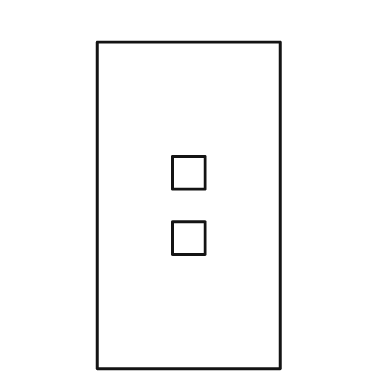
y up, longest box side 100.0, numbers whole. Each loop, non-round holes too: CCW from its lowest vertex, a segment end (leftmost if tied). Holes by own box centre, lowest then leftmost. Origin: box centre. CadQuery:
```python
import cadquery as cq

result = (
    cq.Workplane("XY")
    .moveTo(-28.0, -50.0)
    .lineTo(28.0, -50.0)
    .lineTo(28.0, 50.0)
    .lineTo(-28.0, 50.0)
    .close()
    .moveTo(-5.0, -15.0)
    .lineTo(5.0, -15.0)
    .lineTo(5.0, -5.0)
    .lineTo(-5.0, -5.0)
    .close()
    .moveTo(-5.0, 5.0)
    .lineTo(5.0, 5.0)
    .lineTo(5.0, 15.0)
    .lineTo(-5.0, 15.0)
    .close()
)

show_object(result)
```